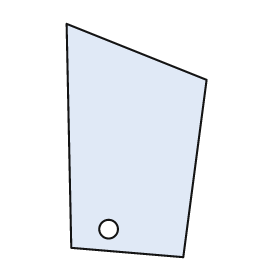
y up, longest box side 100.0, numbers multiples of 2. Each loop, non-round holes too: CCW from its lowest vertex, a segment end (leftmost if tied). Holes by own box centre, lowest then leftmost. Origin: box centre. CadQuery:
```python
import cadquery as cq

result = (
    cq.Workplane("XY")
    .moveTo(20.0, -50.0)
    .lineTo(30.0, 26.0)
    .lineTo(-30.0, 50.0)
    .lineTo(-28.0, -46.0)
    .close()
    .moveTo(-12.0, -38.0)
    .circle(4.0)
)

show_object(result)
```